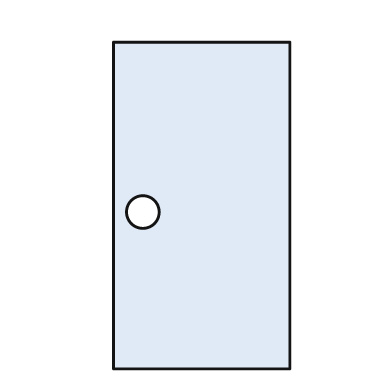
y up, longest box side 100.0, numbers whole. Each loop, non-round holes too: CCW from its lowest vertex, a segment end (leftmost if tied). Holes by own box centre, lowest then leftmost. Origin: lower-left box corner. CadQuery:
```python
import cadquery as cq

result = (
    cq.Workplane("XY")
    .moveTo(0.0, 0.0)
    .lineTo(54.0, 0.0)
    .lineTo(54.0, 100.0)
    .lineTo(0.0, 100.0)
    .close()
    .moveTo(9.0, 48.0)
    .circle(5.0)
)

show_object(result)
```